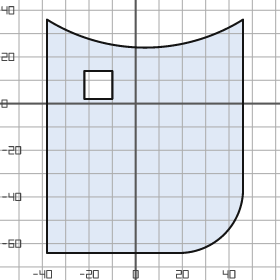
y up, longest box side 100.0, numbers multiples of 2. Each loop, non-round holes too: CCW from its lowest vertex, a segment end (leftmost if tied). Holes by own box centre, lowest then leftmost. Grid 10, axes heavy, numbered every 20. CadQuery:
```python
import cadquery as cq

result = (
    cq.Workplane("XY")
    .moveTo(-38.0, -64.0)
    .lineTo(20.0, -64.0)
    .threePointArc((38.0, -56.0), (46.0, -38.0))
    .lineTo(46.0, 36.0)
    .threePointArc((4.0, 24.0), (-38.0, 36.0))
    .close()
    .moveTo(-22.0, 2.0)
    .lineTo(-10.0, 2.0)
    .lineTo(-10.0, 14.0)
    .lineTo(-22.0, 14.0)
    .close()
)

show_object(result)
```